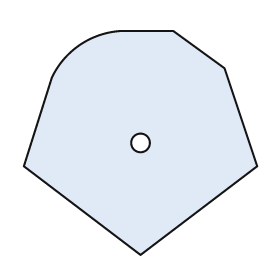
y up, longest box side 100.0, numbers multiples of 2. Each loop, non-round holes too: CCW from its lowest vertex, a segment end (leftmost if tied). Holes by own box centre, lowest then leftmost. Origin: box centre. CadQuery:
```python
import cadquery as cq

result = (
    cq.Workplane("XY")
    .moveTo(0.0, -48.0)
    .lineTo(50.0, -10.0)
    .lineTo(36.0, 32.0)
    .lineTo(14.0, 48.0)
    .lineTo(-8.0, 48.0)
    .threePointArc((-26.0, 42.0), (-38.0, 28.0))
    .lineTo(-50.0, -10.0)
    .close()
    .moveTo(0.0, 0.0)
    .circle(4.0)
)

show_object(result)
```